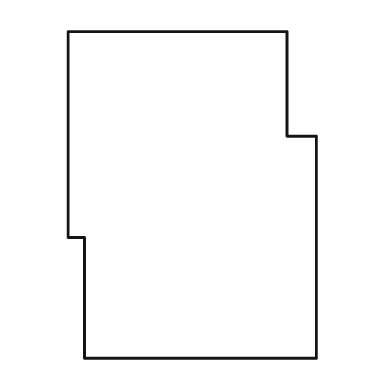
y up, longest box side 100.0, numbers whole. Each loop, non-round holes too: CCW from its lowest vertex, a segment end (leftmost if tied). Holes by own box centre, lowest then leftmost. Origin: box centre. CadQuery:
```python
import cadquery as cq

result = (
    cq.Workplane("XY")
    .moveTo(-33.0, -50.0)
    .lineTo(38.0, -50.0)
    .lineTo(38.0, 18.0)
    .lineTo(29.0, 18.0)
    .lineTo(29.0, 50.0)
    .lineTo(-38.0, 50.0)
    .lineTo(-38.0, -13.0)
    .lineTo(-33.0, -13.0)
    .close()
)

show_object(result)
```